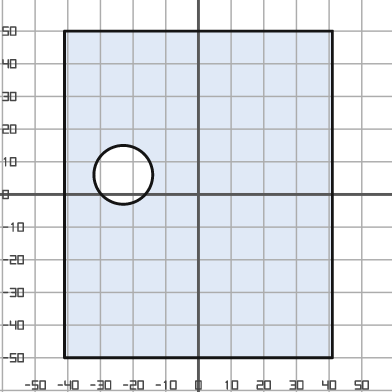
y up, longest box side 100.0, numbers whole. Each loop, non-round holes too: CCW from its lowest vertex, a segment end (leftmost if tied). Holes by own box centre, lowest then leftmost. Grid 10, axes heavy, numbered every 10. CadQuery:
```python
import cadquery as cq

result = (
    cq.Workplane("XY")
    .moveTo(-41.0, -50.0)
    .lineTo(41.0, -50.0)
    .lineTo(41.0, 50.0)
    .lineTo(-41.0, 50.0)
    .close()
    .moveTo(-23.0, 6.0)
    .circle(9.0)
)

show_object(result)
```